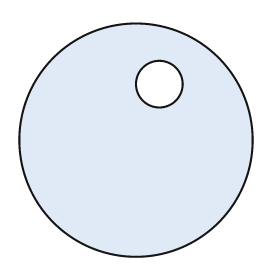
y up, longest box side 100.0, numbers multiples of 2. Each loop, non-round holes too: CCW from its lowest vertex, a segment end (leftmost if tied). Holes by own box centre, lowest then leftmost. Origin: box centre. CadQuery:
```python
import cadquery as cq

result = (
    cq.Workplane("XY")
    .moveTo(0.0, 0.0)
    .circle(50.0)
    .moveTo(10.0, 24.0)
    .circle(10.0)
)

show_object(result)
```